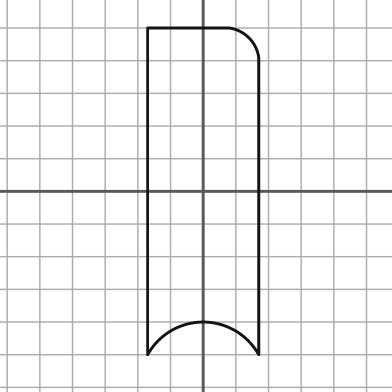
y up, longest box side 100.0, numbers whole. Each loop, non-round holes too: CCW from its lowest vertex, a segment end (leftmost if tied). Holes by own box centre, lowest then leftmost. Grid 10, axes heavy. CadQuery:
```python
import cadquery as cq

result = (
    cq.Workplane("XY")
    .moveTo(-17.0, -50.0)
    .threePointArc((0.0, -40.0), (17.0, -50.0))
    .lineTo(17.0, 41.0)
    .threePointArc((14.0, 47.0), (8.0, 50.0))
    .lineTo(-17.0, 50.0)
    .close()
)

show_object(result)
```